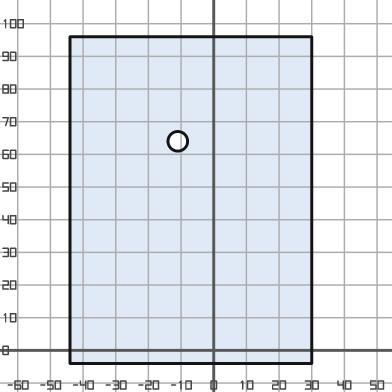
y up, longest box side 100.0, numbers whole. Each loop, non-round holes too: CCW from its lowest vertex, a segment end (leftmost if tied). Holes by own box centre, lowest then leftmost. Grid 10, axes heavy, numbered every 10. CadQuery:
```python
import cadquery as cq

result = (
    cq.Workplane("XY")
    .moveTo(-44.0, -4.0)
    .lineTo(30.0, -4.0)
    .lineTo(30.0, 96.0)
    .lineTo(-44.0, 96.0)
    .close()
    .moveTo(-11.0, 64.0)
    .circle(3.0)
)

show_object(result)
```